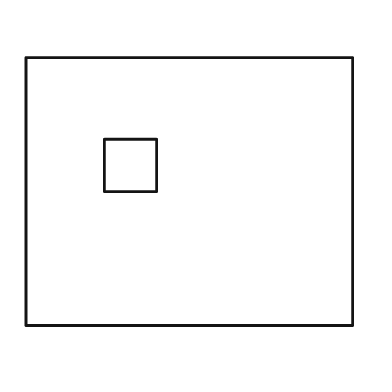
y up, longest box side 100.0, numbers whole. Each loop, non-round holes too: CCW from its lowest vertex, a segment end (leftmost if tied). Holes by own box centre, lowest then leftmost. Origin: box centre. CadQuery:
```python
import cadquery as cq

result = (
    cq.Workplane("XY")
    .moveTo(-50.0, -41.0)
    .lineTo(50.0, -41.0)
    .lineTo(50.0, 41.0)
    .lineTo(-50.0, 41.0)
    .close()
    .moveTo(-26.0, 0.0)
    .lineTo(-10.0, 0.0)
    .lineTo(-10.0, 16.0)
    .lineTo(-26.0, 16.0)
    .close()
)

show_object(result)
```